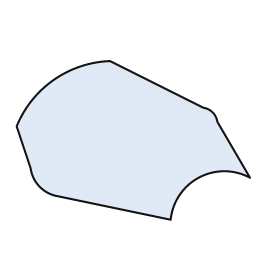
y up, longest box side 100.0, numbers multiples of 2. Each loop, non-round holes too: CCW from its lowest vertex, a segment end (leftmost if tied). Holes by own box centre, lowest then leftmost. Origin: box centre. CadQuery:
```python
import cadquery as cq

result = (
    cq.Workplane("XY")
    .moveTo(16.0, -34.0)
    .threePointArc((28.0, -16.0), (50.0, -16.0))
    .lineTo(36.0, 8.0)
    .threePointArc((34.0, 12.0), (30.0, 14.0))
    .lineTo(-10.0, 34.0)
    .threePointArc((-34.0, 26.0), (-50.0, 6.0))
    .lineTo(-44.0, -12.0)
    .threePointArc((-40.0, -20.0), (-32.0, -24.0))
    .close()
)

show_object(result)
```